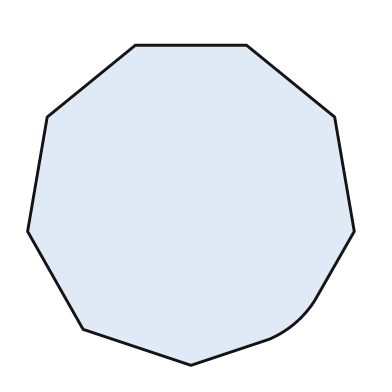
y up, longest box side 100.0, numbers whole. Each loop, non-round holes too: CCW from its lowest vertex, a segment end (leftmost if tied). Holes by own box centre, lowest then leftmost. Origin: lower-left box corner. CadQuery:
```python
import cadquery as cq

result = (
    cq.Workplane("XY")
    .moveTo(50.0, 0.0)
    .lineTo(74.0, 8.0)
    .threePointArc((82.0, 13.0), (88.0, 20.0))
    .lineTo(100.0, 41.0)
    .lineTo(94.0, 76.0)
    .lineTo(67.0, 98.0)
    .lineTo(33.0, 98.0)
    .lineTo(6.0, 76.0)
    .lineTo(0.0, 41.0)
    .lineTo(17.0, 11.0)
    .close()
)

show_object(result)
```